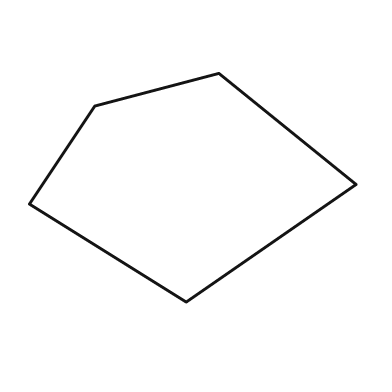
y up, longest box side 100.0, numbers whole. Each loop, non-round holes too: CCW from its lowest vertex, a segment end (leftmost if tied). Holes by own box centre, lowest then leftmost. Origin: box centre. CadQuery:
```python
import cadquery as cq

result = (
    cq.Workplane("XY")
    .moveTo(-2.0, -35.0)
    .lineTo(50.0, 1.0)
    .lineTo(8.0, 35.0)
    .lineTo(-30.0, 25.0)
    .lineTo(-50.0, -5.0)
    .close()
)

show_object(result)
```